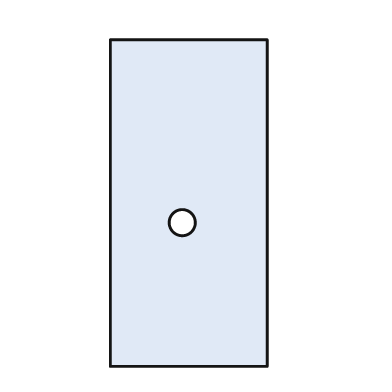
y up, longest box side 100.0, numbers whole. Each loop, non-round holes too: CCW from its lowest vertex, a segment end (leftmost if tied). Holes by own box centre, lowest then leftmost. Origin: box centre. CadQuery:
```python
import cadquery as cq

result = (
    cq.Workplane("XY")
    .moveTo(-24.0, -50.0)
    .lineTo(24.0, -50.0)
    .lineTo(24.0, 50.0)
    .lineTo(-24.0, 50.0)
    .close()
    .moveTo(-2.0, -6.0)
    .circle(4.0)
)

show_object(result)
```